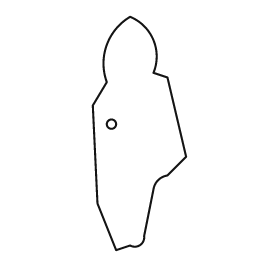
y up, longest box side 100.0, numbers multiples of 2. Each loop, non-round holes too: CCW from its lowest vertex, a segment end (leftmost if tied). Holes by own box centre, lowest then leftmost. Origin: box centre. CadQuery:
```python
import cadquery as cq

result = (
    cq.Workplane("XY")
    .moveTo(-10.0, -50.0)
    .lineTo(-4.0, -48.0)
    .threePointArc((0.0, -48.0), (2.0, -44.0))
    .lineTo(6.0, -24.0)
    .threePointArc((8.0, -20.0), (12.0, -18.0))
    .lineTo(20.0, -10.0)
    .lineTo(12.0, 24.0)
    .lineTo(6.0, 26.0)
    .threePointArc((6.0, 40.0), (-4.0, 50.0))
    .threePointArc((-14.0, 38.0), (-14.0, 22.0))
    .lineTo(-20.0, 12.0)
    .lineTo(-18.0, -30.0)
    .close()
    .moveTo(-12.0, 4.0)
    .circle(2.0)
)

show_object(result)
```